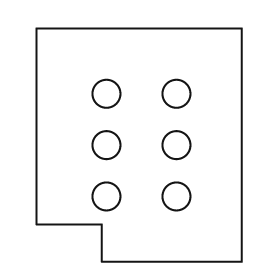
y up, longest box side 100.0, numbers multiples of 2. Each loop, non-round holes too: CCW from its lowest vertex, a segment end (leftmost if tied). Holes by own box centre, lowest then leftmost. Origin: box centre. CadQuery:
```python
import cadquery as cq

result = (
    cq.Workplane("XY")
    .moveTo(-16.0, -50.0)
    .lineTo(44.0, -50.0)
    .lineTo(44.0, 50.0)
    .lineTo(-44.0, 50.0)
    .lineTo(-44.0, -34.0)
    .lineTo(-16.0, -34.0)
    .close()
    .moveTo(-14.0, -22.0)
    .circle(6.0)
    .moveTo(16.0, -22.0)
    .circle(6.0)
    .moveTo(-14.0, 0.0)
    .circle(6.0)
    .moveTo(16.0, 0.0)
    .circle(6.0)
    .moveTo(-14.0, 22.0)
    .circle(6.0)
    .moveTo(16.0, 22.0)
    .circle(6.0)
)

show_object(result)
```